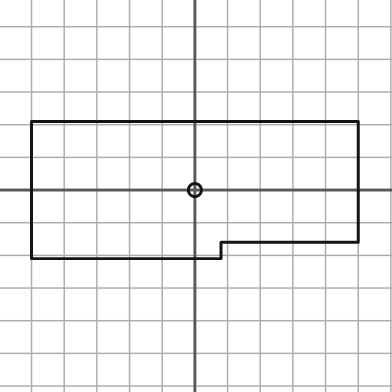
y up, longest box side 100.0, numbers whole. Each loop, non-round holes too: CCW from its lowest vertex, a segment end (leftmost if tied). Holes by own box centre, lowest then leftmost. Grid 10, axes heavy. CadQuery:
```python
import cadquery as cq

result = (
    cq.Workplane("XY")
    .moveTo(-50.0, -21.0)
    .lineTo(8.0, -21.0)
    .lineTo(8.0, -16.0)
    .lineTo(50.0, -16.0)
    .lineTo(50.0, 21.0)
    .lineTo(-50.0, 21.0)
    .close()
    .moveTo(0.0, 0.0)
    .circle(2.0)
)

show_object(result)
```